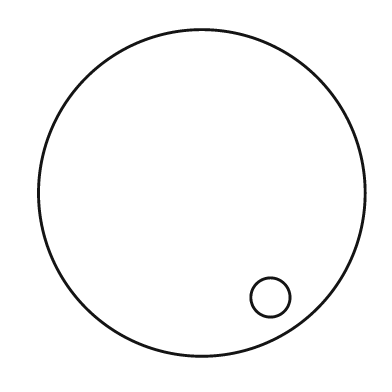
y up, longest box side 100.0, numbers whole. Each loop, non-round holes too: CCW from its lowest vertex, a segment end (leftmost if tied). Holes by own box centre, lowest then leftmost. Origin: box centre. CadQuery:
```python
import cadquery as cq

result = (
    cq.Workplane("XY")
    .moveTo(0.0, 0.0)
    .circle(50.0)
    .moveTo(21.0, -32.0)
    .circle(6.0)
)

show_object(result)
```